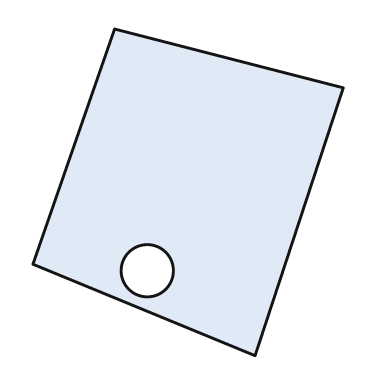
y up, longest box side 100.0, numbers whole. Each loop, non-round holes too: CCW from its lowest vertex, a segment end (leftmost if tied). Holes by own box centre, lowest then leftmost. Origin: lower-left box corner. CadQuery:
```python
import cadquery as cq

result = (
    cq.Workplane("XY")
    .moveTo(68.0, 0.0)
    .lineTo(95.0, 82.0)
    .lineTo(25.0, 100.0)
    .lineTo(0.0, 28.0)
    .close()
    .moveTo(35.0, 26.0)
    .circle(8.0)
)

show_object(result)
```